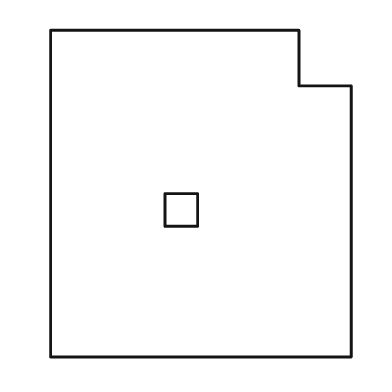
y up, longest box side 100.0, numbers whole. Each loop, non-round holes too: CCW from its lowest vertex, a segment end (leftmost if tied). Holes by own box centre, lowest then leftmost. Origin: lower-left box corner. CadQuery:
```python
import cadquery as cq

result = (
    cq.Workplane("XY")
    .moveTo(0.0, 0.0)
    .lineTo(92.0, 0.0)
    .lineTo(92.0, 83.0)
    .lineTo(76.0, 83.0)
    .lineTo(76.0, 100.0)
    .lineTo(0.0, 100.0)
    .close()
    .moveTo(35.0, 40.0)
    .lineTo(45.0, 40.0)
    .lineTo(45.0, 50.0)
    .lineTo(35.0, 50.0)
    .close()
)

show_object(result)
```